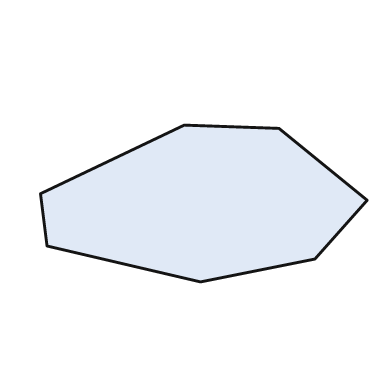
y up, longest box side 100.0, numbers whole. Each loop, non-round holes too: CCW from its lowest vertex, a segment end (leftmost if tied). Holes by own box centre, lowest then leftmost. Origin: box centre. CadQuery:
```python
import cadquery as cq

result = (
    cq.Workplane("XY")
    .moveTo(-1.0, -24.0)
    .lineTo(34.0, -17.0)
    .lineTo(50.0, 1.0)
    .lineTo(23.0, 23.0)
    .lineTo(-6.0, 24.0)
    .lineTo(-50.0, 3.0)
    .lineTo(-48.0, -13.0)
    .close()
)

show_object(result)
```